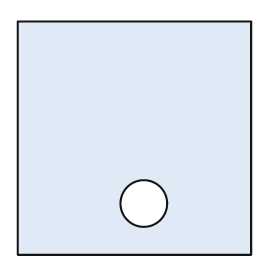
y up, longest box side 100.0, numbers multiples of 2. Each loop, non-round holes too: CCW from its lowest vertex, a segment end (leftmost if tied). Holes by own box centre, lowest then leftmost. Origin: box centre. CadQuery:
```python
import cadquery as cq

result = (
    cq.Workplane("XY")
    .moveTo(-50.0, -50.0)
    .lineTo(50.0, -50.0)
    .lineTo(50.0, 50.0)
    .lineTo(-50.0, 50.0)
    .close()
    .moveTo(4.0, -28.0)
    .circle(10.0)
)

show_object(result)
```